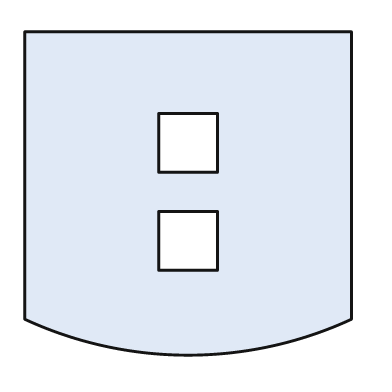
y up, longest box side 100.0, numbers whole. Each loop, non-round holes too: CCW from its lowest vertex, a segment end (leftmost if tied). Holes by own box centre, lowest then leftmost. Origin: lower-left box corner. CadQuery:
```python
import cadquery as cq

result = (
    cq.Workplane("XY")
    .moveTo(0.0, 11.0)
    .threePointArc((50.0, 0.0), (100.0, 11.0))
    .lineTo(100.0, 99.0)
    .lineTo(0.0, 99.0)
    .close()
    .moveTo(41.0, 26.0)
    .lineTo(59.0, 26.0)
    .lineTo(59.0, 44.0)
    .lineTo(41.0, 44.0)
    .close()
    .moveTo(41.0, 56.0)
    .lineTo(59.0, 56.0)
    .lineTo(59.0, 74.0)
    .lineTo(41.0, 74.0)
    .close()
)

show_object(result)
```